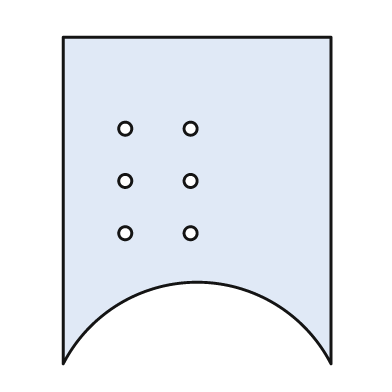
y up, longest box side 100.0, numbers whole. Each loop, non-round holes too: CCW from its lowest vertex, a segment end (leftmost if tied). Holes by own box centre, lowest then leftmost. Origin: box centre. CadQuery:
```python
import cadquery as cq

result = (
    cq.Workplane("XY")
    .moveTo(-41.0, -50.0)
    .threePointArc((0.0, -25.0), (41.0, -50.0))
    .lineTo(41.0, 50.0)
    .lineTo(-41.0, 50.0)
    .close()
    .moveTo(-22.0, -10.0)
    .circle(2.0)
    .moveTo(-2.0, -10.0)
    .circle(2.0)
    .moveTo(-22.0, 6.0)
    .circle(2.0)
    .moveTo(-2.0, 6.0)
    .circle(2.0)
    .moveTo(-22.0, 22.0)
    .circle(2.0)
    .moveTo(-2.0, 22.0)
    .circle(2.0)
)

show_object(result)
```